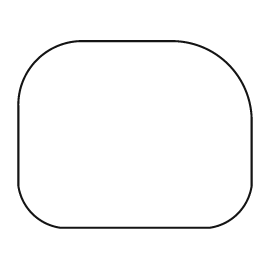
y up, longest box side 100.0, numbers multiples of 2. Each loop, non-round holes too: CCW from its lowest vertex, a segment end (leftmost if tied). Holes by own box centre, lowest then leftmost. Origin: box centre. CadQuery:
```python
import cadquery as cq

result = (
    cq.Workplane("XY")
    .moveTo(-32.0, -40.0)
    .lineTo(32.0, -40.0)
    .threePointArc((44.0, -34.0), (50.0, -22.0))
    .lineTo(50.0, 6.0)
    .threePointArc((40.0, 30.0), (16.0, 40.0))
    .lineTo(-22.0, 40.0)
    .threePointArc((-42.0, 32.0), (-50.0, 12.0))
    .lineTo(-50.0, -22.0)
    .threePointArc((-44.0, -34.0), (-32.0, -40.0))
    .close()
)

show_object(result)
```